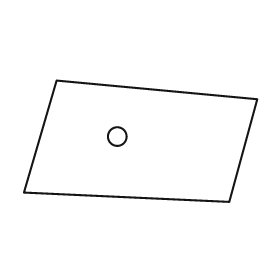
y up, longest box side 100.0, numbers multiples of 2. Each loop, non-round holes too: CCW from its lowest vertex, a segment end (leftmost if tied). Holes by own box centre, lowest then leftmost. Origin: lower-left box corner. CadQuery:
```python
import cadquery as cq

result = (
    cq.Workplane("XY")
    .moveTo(88.0, 0.0)
    .lineTo(100.0, 44.0)
    .lineTo(14.0, 52.0)
    .lineTo(0.0, 4.0)
    .close()
    .moveTo(40.0, 28.0)
    .circle(4.0)
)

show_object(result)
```